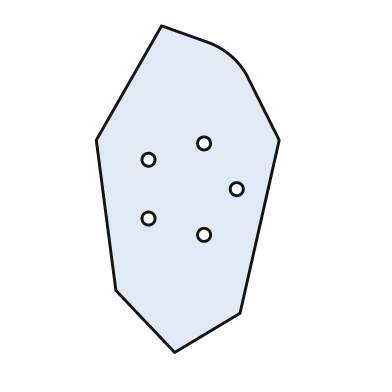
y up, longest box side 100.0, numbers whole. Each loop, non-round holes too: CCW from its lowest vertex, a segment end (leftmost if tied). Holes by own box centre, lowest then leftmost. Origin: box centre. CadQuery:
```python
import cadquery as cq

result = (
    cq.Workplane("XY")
    .moveTo(-4.0, -50.0)
    .lineTo(16.0, -38.0)
    .lineTo(28.0, 15.0)
    .lineTo(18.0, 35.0)
    .threePointArc((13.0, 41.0), (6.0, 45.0))
    .lineTo(-8.0, 50.0)
    .lineTo(-28.0, 15.0)
    .lineTo(-22.0, -31.0)
    .close()
    .moveTo(5.0, -14.0)
    .circle(2.0)
    .moveTo(-12.0, -9.0)
    .circle(2.0)
    .moveTo(15.0, 0.0)
    .circle(2.0)
    .moveTo(-12.0, 9.0)
    .circle(2.0)
    .moveTo(5.0, 14.0)
    .circle(2.0)
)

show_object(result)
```